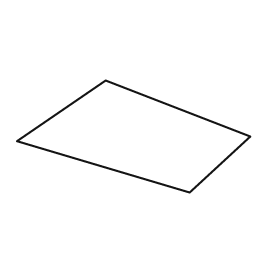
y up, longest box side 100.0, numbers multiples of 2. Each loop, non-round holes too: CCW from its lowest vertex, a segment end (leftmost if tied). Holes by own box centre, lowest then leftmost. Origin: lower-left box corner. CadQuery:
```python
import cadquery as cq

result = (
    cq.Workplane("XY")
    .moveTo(74.0, 0.0)
    .lineTo(100.0, 24.0)
    .lineTo(38.0, 48.0)
    .lineTo(0.0, 22.0)
    .close()
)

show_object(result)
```